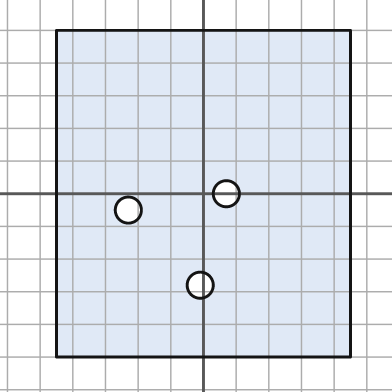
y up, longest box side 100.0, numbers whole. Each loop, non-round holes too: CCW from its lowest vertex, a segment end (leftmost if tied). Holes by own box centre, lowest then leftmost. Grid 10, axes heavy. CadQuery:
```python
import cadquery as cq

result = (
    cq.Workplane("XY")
    .moveTo(-45.0, -50.0)
    .lineTo(45.0, -50.0)
    .lineTo(45.0, 50.0)
    .lineTo(-45.0, 50.0)
    .close()
    .moveTo(-1.0, -28.0)
    .circle(4.0)
    .moveTo(-23.0, -5.0)
    .circle(4.0)
    .moveTo(7.0, 0.0)
    .circle(4.0)
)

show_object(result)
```